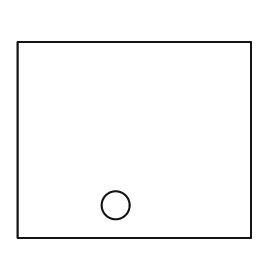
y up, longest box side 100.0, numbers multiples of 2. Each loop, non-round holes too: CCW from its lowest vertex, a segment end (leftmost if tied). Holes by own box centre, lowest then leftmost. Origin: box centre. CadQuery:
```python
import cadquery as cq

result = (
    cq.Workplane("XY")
    .moveTo(-50.0, -42.0)
    .lineTo(50.0, -42.0)
    .lineTo(50.0, 42.0)
    .lineTo(-50.0, 42.0)
    .close()
    .moveTo(-8.0, -28.0)
    .circle(6.0)
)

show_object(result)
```